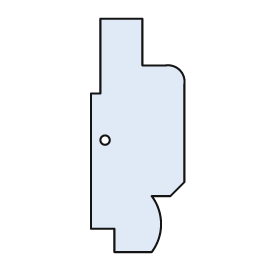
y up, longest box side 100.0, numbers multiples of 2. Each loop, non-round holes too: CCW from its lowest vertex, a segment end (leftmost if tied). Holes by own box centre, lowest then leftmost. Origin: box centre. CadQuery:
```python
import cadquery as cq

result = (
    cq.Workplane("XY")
    .moveTo(-10.0, -50.0)
    .lineTo(6.0, -50.0)
    .threePointArc((10.0, -38.0), (6.0, -26.0))
    .lineTo(14.0, -26.0)
    .lineTo(20.0, -20.0)
    .lineTo(20.0, 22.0)
    .threePointArc((18.0, 28.0), (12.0, 30.0))
    .lineTo(2.0, 30.0)
    .lineTo(2.0, 50.0)
    .lineTo(-16.0, 50.0)
    .lineTo(-16.0, 18.0)
    .lineTo(-20.0, 18.0)
    .lineTo(-20.0, -40.0)
    .lineTo(-10.0, -40.0)
    .close()
    .moveTo(-14.0, -2.0)
    .circle(2.0)
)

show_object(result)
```